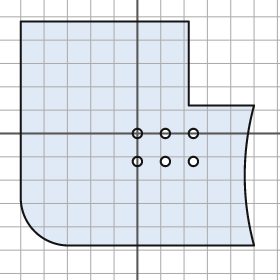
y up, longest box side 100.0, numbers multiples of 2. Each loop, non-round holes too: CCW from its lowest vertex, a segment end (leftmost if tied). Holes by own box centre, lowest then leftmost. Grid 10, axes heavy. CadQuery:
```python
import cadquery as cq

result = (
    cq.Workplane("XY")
    .moveTo(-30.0, -48.0)
    .lineTo(50.0, -48.0)
    .threePointArc((46.0, -18.0), (50.0, 12.0))
    .lineTo(22.0, 12.0)
    .lineTo(22.0, 48.0)
    .lineTo(-50.0, 48.0)
    .lineTo(-50.0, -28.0)
    .threePointArc((-44.0, -42.0), (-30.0, -48.0))
    .close()
    .moveTo(0.0, -12.0)
    .circle(2.0)
    .moveTo(12.0, -12.0)
    .circle(2.0)
    .moveTo(24.0, -12.0)
    .circle(2.0)
    .moveTo(0.0, 0.0)
    .circle(2.0)
    .moveTo(12.0, 0.0)
    .circle(2.0)
    .moveTo(24.0, 0.0)
    .circle(2.0)
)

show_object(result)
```